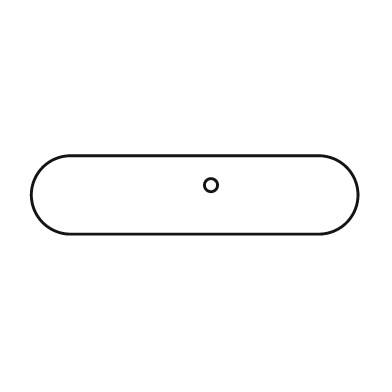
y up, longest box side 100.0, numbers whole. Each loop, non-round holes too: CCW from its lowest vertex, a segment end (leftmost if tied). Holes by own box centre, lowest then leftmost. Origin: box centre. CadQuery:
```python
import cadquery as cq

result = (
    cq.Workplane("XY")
    .moveTo(-38.0, -12.0)
    .lineTo(38.0, -12.0)
    .threePointArc((50.0, 0.0), (38.0, 12.0))
    .lineTo(-38.0, 12.0)
    .threePointArc((-50.0, 0.0), (-38.0, -12.0))
    .close()
    .moveTo(5.0, 3.0)
    .circle(2.0)
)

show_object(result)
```